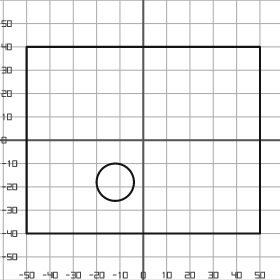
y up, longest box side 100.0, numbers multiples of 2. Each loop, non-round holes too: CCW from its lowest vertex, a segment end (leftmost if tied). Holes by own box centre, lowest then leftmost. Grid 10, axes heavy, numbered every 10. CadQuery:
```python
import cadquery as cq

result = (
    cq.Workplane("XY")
    .moveTo(-50.0, -40.0)
    .lineTo(50.0, -40.0)
    .lineTo(50.0, 40.0)
    .lineTo(-50.0, 40.0)
    .close()
    .moveTo(-12.0, -18.0)
    .circle(8.0)
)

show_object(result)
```